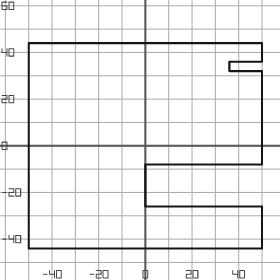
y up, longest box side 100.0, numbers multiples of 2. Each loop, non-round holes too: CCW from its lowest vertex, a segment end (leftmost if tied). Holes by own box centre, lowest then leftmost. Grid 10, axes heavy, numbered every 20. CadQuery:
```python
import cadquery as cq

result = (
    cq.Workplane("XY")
    .moveTo(-50.0, -44.0)
    .lineTo(50.0, -44.0)
    .lineTo(50.0, -26.0)
    .lineTo(0.0, -26.0)
    .lineTo(0.0, -8.0)
    .lineTo(50.0, -8.0)
    .lineTo(50.0, 32.0)
    .lineTo(36.0, 32.0)
    .lineTo(36.0, 36.0)
    .lineTo(50.0, 36.0)
    .lineTo(50.0, 44.0)
    .lineTo(-50.0, 44.0)
    .close()
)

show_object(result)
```